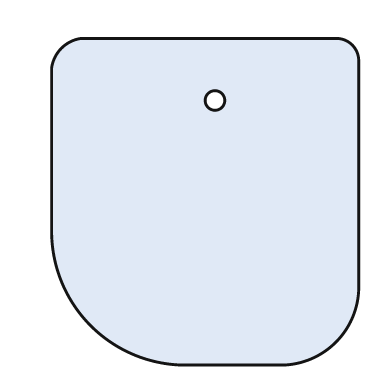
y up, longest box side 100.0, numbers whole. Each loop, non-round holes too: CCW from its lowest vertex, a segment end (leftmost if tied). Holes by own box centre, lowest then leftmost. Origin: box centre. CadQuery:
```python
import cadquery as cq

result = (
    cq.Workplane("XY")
    .moveTo(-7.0, -50.0)
    .lineTo(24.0, -50.0)
    .threePointArc((40.0, -43.0), (47.0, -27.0))
    .lineTo(47.0, 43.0)
    .threePointArc((45.0, 48.0), (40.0, 50.0))
    .lineTo(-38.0, 50.0)
    .threePointArc((-44.0, 47.0), (-47.0, 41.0))
    .lineTo(-47.0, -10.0)
    .threePointArc((-35.0, -38.0), (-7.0, -50.0))
    .close()
    .moveTo(3.0, 31.0)
    .circle(3.0)
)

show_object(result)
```